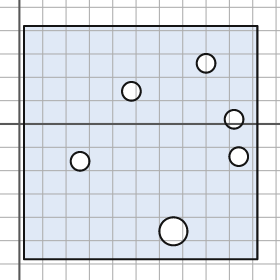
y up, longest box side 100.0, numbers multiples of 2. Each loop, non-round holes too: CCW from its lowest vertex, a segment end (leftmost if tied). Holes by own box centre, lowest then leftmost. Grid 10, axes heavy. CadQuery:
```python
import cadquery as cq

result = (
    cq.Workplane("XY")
    .moveTo(2.0, -58.0)
    .lineTo(102.0, -58.0)
    .lineTo(102.0, 42.0)
    .lineTo(2.0, 42.0)
    .close()
    .moveTo(66.0, -46.0)
    .circle(6.0)
    .moveTo(26.0, -16.0)
    .circle(4.0)
    .moveTo(94.0, -14.0)
    .circle(4.0)
    .moveTo(92.0, 2.0)
    .circle(4.0)
    .moveTo(48.0, 14.0)
    .circle(4.0)
    .moveTo(80.0, 26.0)
    .circle(4.0)
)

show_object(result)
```